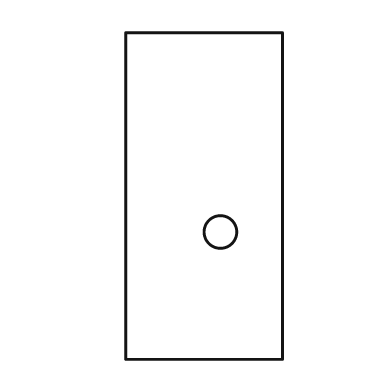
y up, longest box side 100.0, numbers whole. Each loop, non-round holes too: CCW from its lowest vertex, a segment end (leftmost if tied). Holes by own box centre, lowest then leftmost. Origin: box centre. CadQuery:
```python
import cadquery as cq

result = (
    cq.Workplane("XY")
    .moveTo(-24.0, -50.0)
    .lineTo(24.0, -50.0)
    .lineTo(24.0, 50.0)
    .lineTo(-24.0, 50.0)
    .close()
    .moveTo(5.0, -11.0)
    .circle(5.0)
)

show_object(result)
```